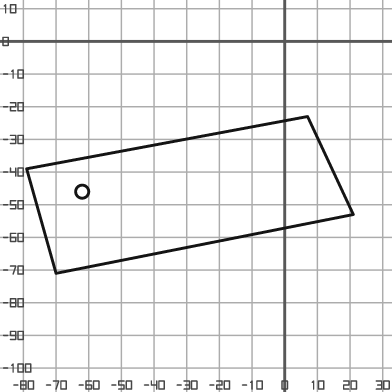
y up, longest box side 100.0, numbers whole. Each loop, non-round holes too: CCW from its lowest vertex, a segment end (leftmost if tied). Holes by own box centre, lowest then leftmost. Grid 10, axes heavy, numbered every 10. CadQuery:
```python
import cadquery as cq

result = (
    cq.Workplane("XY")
    .moveTo(-70.0, -71.0)
    .lineTo(21.0, -53.0)
    .lineTo(7.0, -23.0)
    .lineTo(-79.0, -39.0)
    .close()
    .moveTo(-62.0, -46.0)
    .circle(2.0)
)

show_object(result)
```